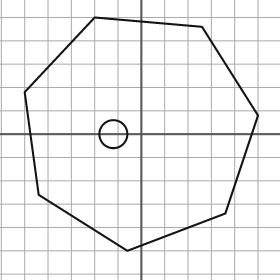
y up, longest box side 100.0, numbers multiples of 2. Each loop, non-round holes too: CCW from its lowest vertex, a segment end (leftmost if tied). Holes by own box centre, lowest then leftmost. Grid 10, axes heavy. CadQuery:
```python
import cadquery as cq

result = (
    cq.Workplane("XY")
    .moveTo(-6.0, -50.0)
    .lineTo(36.0, -34.0)
    .lineTo(50.0, 8.0)
    .lineTo(26.0, 46.0)
    .lineTo(-20.0, 50.0)
    .lineTo(-50.0, 18.0)
    .lineTo(-44.0, -26.0)
    .close()
    .moveTo(-12.0, 0.0)
    .circle(6.0)
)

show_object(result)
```